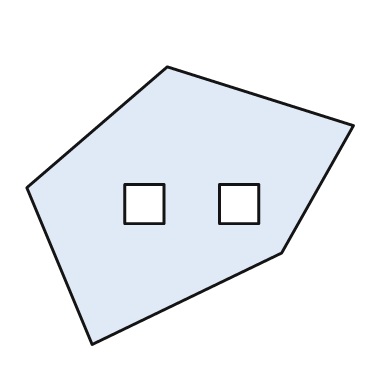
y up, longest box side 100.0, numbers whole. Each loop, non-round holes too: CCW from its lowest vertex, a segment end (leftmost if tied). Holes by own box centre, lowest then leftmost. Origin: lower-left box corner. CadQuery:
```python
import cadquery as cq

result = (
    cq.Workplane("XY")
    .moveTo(20.0, 0.0)
    .lineTo(78.0, 28.0)
    .lineTo(100.0, 67.0)
    .lineTo(43.0, 85.0)
    .lineTo(0.0, 48.0)
    .close()
    .moveTo(30.0, 37.0)
    .lineTo(42.0, 37.0)
    .lineTo(42.0, 49.0)
    .lineTo(30.0, 49.0)
    .close()
    .moveTo(59.0, 37.0)
    .lineTo(71.0, 37.0)
    .lineTo(71.0, 49.0)
    .lineTo(59.0, 49.0)
    .close()
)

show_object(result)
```